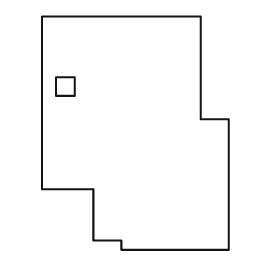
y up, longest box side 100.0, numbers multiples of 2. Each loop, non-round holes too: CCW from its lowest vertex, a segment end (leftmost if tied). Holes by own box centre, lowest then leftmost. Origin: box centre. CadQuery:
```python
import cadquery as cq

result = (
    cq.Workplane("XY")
    .moveTo(-6.0, -50.0)
    .lineTo(40.0, -50.0)
    .lineTo(40.0, 6.0)
    .lineTo(28.0, 6.0)
    .lineTo(28.0, 50.0)
    .lineTo(-40.0, 50.0)
    .lineTo(-40.0, -24.0)
    .lineTo(-18.0, -24.0)
    .lineTo(-18.0, -46.0)
    .lineTo(-6.0, -46.0)
    .close()
    .moveTo(-34.0, 16.0)
    .lineTo(-26.0, 16.0)
    .lineTo(-26.0, 24.0)
    .lineTo(-34.0, 24.0)
    .close()
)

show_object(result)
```